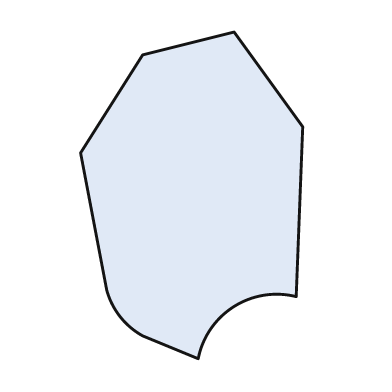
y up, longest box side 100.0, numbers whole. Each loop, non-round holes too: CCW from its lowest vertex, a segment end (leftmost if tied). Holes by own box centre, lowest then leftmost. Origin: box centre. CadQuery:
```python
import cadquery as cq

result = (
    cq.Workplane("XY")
    .moveTo(2.0, -50.0)
    .threePointArc((13.0, -34.0), (32.0, -31.0))
    .lineTo(34.0, 21.0)
    .lineTo(13.0, 50.0)
    .lineTo(-15.0, 43.0)
    .lineTo(-34.0, 13.0)
    .lineTo(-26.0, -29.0)
    .threePointArc((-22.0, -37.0), (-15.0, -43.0))
    .close()
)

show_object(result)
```